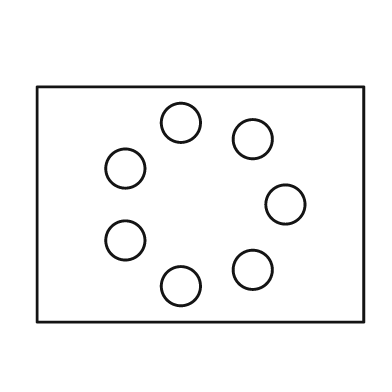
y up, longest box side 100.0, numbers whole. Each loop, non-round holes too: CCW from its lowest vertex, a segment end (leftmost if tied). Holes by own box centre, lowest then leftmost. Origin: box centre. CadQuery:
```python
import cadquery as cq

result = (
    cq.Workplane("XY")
    .moveTo(-50.0, -36.0)
    .lineTo(50.0, -36.0)
    .lineTo(50.0, 36.0)
    .lineTo(-50.0, 36.0)
    .close()
    .moveTo(-6.0, -25.0)
    .circle(6.0)
    .moveTo(16.0, -20.0)
    .circle(6.0)
    .moveTo(-23.0, -11.0)
    .circle(6.0)
    .moveTo(26.0, 0.0)
    .circle(6.0)
    .moveTo(-23.0, 11.0)
    .circle(6.0)
    .moveTo(16.0, 20.0)
    .circle(6.0)
    .moveTo(-6.0, 25.0)
    .circle(6.0)
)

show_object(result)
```